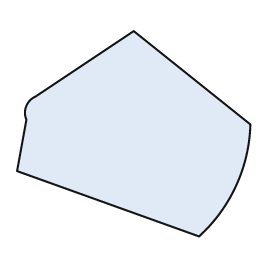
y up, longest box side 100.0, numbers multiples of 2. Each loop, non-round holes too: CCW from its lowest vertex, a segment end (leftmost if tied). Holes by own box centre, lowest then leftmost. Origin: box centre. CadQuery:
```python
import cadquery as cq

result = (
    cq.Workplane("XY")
    .moveTo(28.0, -44.0)
    .threePointArc((44.0, -22.0), (50.0, 4.0))
    .lineTo(0.0, 44.0)
    .lineTo(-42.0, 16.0)
    .threePointArc((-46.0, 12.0), (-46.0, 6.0))
    .lineTo(-50.0, -16.0)
    .close()
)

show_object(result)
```